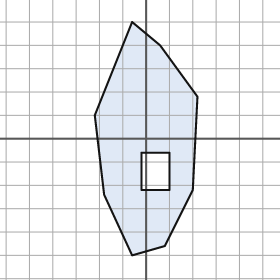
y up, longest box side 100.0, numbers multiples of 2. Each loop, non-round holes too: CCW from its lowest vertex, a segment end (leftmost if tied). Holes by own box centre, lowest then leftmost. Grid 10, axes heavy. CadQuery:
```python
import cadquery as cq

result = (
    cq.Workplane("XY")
    .moveTo(-6.0, -50.0)
    .lineTo(8.0, -46.0)
    .lineTo(20.0, -22.0)
    .lineTo(22.0, 18.0)
    .lineTo(6.0, 40.0)
    .lineTo(-6.0, 50.0)
    .lineTo(-22.0, 10.0)
    .lineTo(-18.0, -24.0)
    .close()
    .moveTo(-2.0, -22.0)
    .lineTo(10.0, -22.0)
    .lineTo(10.0, -6.0)
    .lineTo(-2.0, -6.0)
    .close()
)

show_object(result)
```